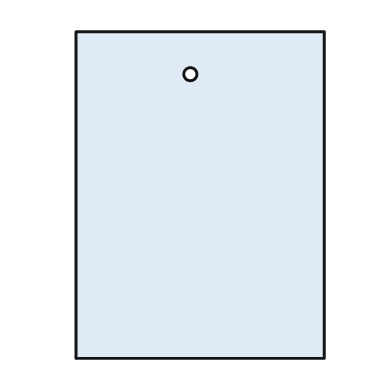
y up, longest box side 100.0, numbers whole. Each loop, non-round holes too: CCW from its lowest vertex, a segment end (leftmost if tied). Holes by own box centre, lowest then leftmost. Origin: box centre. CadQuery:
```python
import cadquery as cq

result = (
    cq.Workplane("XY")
    .moveTo(-38.0, -50.0)
    .lineTo(38.0, -50.0)
    .lineTo(38.0, 50.0)
    .lineTo(-38.0, 50.0)
    .close()
    .moveTo(-3.0, 37.0)
    .circle(2.0)
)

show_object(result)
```